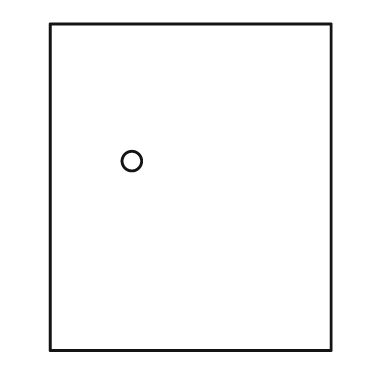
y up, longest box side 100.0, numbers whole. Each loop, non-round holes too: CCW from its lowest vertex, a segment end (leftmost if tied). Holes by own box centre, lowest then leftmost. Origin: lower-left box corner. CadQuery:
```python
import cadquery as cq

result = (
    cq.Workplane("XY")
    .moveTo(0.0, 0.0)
    .lineTo(86.0, 0.0)
    .lineTo(86.0, 100.0)
    .lineTo(0.0, 100.0)
    .close()
    .moveTo(25.0, 58.0)
    .circle(3.0)
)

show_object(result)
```